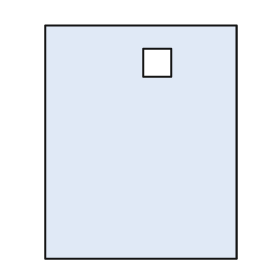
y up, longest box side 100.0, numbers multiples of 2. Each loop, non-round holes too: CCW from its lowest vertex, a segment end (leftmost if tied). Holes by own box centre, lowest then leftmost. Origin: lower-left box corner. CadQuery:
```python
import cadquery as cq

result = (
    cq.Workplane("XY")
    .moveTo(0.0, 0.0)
    .lineTo(82.0, 0.0)
    .lineTo(82.0, 100.0)
    .lineTo(0.0, 100.0)
    .close()
    .moveTo(42.0, 78.0)
    .lineTo(54.0, 78.0)
    .lineTo(54.0, 90.0)
    .lineTo(42.0, 90.0)
    .close()
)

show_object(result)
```